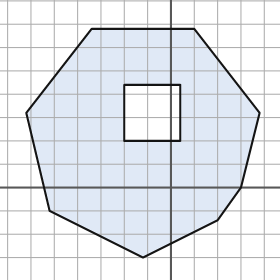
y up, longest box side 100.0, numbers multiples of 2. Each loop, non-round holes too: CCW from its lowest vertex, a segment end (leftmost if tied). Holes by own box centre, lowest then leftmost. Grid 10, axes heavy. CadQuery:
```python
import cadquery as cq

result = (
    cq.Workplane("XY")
    .moveTo(-12.0, -30.0)
    .lineTo(20.0, -14.0)
    .lineTo(30.0, 0.0)
    .lineTo(38.0, 32.0)
    .lineTo(10.0, 68.0)
    .lineTo(-34.0, 68.0)
    .lineTo(-62.0, 32.0)
    .lineTo(-52.0, -10.0)
    .close()
    .moveTo(-20.0, 20.0)
    .lineTo(4.0, 20.0)
    .lineTo(4.0, 44.0)
    .lineTo(-20.0, 44.0)
    .close()
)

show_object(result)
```